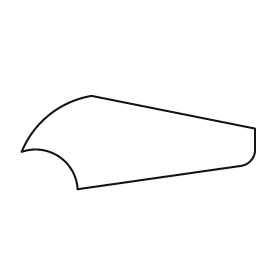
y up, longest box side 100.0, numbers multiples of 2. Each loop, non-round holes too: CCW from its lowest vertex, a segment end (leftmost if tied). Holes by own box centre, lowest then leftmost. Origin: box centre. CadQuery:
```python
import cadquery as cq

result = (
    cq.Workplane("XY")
    .moveTo(-26.0, -20.0)
    .lineTo(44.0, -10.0)
    .threePointArc((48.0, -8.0), (50.0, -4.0))
    .lineTo(50.0, 6.0)
    .lineTo(-20.0, 20.0)
    .threePointArc((-38.0, 12.0), (-50.0, -4.0))
    .threePointArc((-34.0, -6.0), (-26.0, -20.0))
    .close()
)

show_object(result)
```